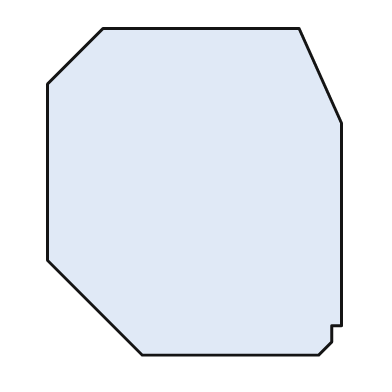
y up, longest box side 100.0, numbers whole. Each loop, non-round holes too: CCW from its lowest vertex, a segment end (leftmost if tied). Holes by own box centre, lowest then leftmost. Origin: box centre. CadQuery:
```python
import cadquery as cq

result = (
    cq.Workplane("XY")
    .moveTo(-16.0, -50.0)
    .lineTo(38.0, -50.0)
    .lineTo(42.0, -46.0)
    .lineTo(42.0, -41.0)
    .lineTo(45.0, -41.0)
    .lineTo(45.0, 21.0)
    .lineTo(32.0, 50.0)
    .lineTo(-28.0, 50.0)
    .lineTo(-45.0, 33.0)
    .lineTo(-45.0, -21.0)
    .close()
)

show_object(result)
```